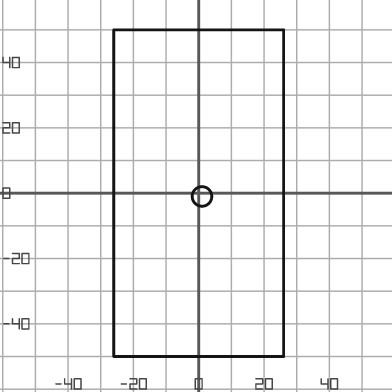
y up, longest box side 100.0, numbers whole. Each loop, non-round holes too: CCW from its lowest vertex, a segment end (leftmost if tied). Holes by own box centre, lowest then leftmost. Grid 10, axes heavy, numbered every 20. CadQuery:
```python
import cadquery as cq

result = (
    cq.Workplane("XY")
    .moveTo(-26.0, -50.0)
    .lineTo(26.0, -50.0)
    .lineTo(26.0, 50.0)
    .lineTo(-26.0, 50.0)
    .close()
    .moveTo(1.0, -1.0)
    .circle(3.0)
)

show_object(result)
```